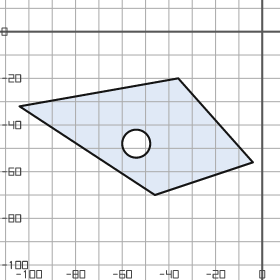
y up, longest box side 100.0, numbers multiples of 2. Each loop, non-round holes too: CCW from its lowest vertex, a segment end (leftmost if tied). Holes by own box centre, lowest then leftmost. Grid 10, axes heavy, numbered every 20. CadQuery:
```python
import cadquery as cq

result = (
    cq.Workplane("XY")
    .moveTo(-46.0, -70.0)
    .lineTo(-4.0, -56.0)
    .lineTo(-36.0, -20.0)
    .lineTo(-104.0, -32.0)
    .close()
    .moveTo(-54.0, -48.0)
    .circle(6.0)
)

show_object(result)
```